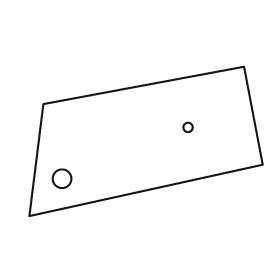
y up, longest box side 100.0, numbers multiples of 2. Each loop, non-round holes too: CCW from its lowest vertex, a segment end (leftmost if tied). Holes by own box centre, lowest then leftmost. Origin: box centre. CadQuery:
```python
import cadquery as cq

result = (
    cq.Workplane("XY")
    .moveTo(-50.0, -32.0)
    .lineTo(50.0, -10.0)
    .lineTo(42.0, 32.0)
    .lineTo(-44.0, 16.0)
    .close()
    .moveTo(-36.0, -16.0)
    .circle(4.0)
    .moveTo(18.0, 6.0)
    .circle(2.0)
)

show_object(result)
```